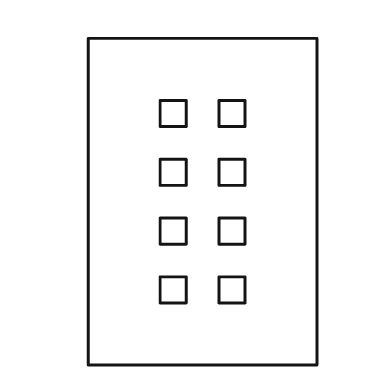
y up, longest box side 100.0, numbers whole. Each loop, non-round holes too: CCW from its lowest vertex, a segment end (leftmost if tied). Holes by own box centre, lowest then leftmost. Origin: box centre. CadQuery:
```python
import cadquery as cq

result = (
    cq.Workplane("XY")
    .moveTo(-35.0, -50.0)
    .lineTo(35.0, -50.0)
    .lineTo(35.0, 50.0)
    .lineTo(-35.0, 50.0)
    .close()
    .moveTo(-13.0, -31.0)
    .lineTo(-5.0, -31.0)
    .lineTo(-5.0, -23.0)
    .lineTo(-13.0, -23.0)
    .close()
    .moveTo(5.0, -31.0)
    .lineTo(13.0, -31.0)
    .lineTo(13.0, -23.0)
    .lineTo(5.0, -23.0)
    .close()
    .moveTo(-13.0, -13.0)
    .lineTo(-5.0, -13.0)
    .lineTo(-5.0, -5.0)
    .lineTo(-13.0, -5.0)
    .close()
    .moveTo(5.0, -13.0)
    .lineTo(13.0, -13.0)
    .lineTo(13.0, -5.0)
    .lineTo(5.0, -5.0)
    .close()
    .moveTo(-13.0, 5.0)
    .lineTo(-5.0, 5.0)
    .lineTo(-5.0, 13.0)
    .lineTo(-13.0, 13.0)
    .close()
    .moveTo(5.0, 5.0)
    .lineTo(13.0, 5.0)
    .lineTo(13.0, 13.0)
    .lineTo(5.0, 13.0)
    .close()
    .moveTo(-13.0, 23.0)
    .lineTo(-5.0, 23.0)
    .lineTo(-5.0, 31.0)
    .lineTo(-13.0, 31.0)
    .close()
    .moveTo(5.0, 23.0)
    .lineTo(13.0, 23.0)
    .lineTo(13.0, 31.0)
    .lineTo(5.0, 31.0)
    .close()
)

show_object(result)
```